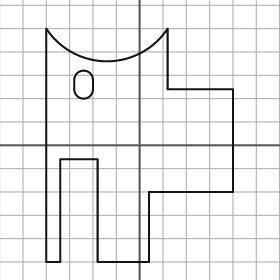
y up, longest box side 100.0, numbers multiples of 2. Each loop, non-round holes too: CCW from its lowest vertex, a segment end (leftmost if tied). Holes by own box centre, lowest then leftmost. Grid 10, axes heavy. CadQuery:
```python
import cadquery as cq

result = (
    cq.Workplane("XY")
    .moveTo(-40.0, -50.0)
    .lineTo(-34.0, -50.0)
    .lineTo(-34.0, -6.0)
    .lineTo(-18.0, -6.0)
    .lineTo(-18.0, -50.0)
    .lineTo(4.0, -50.0)
    .lineTo(4.0, -20.0)
    .lineTo(40.0, -20.0)
    .lineTo(40.0, 24.0)
    .lineTo(12.0, 24.0)
    .lineTo(12.0, 50.0)
    .threePointArc((-14.0, 36.0), (-40.0, 50.0))
    .close()
    .moveTo(-28.0, 24.0)
    .threePointArc((-24.0, 20.0), (-20.0, 24.0))
    .lineTo(-20.0, 28.0)
    .threePointArc((-24.0, 32.0), (-28.0, 28.0))
    .close()
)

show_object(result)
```